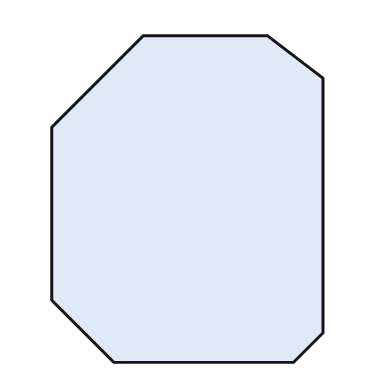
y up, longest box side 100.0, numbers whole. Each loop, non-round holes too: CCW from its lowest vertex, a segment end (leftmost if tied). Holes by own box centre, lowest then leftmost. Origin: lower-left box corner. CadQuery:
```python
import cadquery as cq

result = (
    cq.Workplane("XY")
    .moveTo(19.0, 0.0)
    .lineTo(74.0, 0.0)
    .lineTo(83.0, 9.0)
    .lineTo(83.0, 87.0)
    .lineTo(66.0, 100.0)
    .lineTo(28.0, 100.0)
    .lineTo(0.0, 72.0)
    .lineTo(0.0, 19.0)
    .close()
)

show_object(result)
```